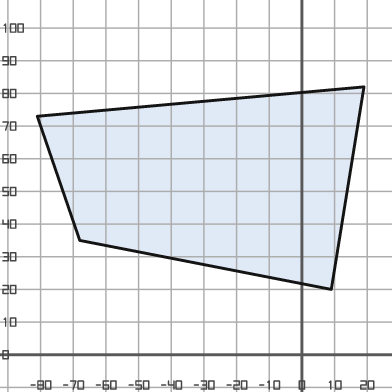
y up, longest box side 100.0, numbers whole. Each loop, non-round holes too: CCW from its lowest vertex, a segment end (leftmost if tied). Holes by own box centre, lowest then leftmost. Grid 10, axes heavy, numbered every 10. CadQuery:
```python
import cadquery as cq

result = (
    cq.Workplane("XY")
    .moveTo(9.0, 20.0)
    .lineTo(19.0, 82.0)
    .lineTo(-81.0, 73.0)
    .lineTo(-68.0, 35.0)
    .close()
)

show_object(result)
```